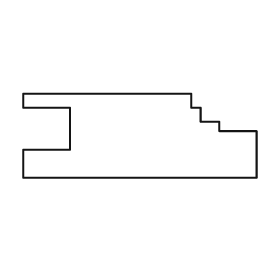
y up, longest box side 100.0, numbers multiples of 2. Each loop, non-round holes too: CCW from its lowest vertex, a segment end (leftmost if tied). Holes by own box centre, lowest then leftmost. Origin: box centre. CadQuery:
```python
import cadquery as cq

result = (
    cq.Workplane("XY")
    .moveTo(-50.0, -18.0)
    .lineTo(50.0, -18.0)
    .lineTo(50.0, 2.0)
    .lineTo(34.0, 2.0)
    .lineTo(34.0, 6.0)
    .lineTo(26.0, 6.0)
    .lineTo(26.0, 12.0)
    .lineTo(22.0, 12.0)
    .lineTo(22.0, 18.0)
    .lineTo(-50.0, 18.0)
    .lineTo(-50.0, 12.0)
    .lineTo(-30.0, 12.0)
    .lineTo(-30.0, -6.0)
    .lineTo(-50.0, -6.0)
    .close()
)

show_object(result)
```